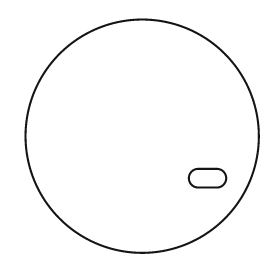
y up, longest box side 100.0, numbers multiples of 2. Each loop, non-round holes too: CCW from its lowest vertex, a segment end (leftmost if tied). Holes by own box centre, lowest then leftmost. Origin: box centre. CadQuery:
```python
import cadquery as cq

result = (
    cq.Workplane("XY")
    .moveTo(0.0, 0.0)
    .circle(50.0)
    .moveTo(24.0, -22.0)
    .lineTo(32.0, -22.0)
    .threePointArc((36.0, -18.0), (32.0, -14.0))
    .lineTo(24.0, -14.0)
    .threePointArc((20.0, -18.0), (24.0, -22.0))
    .close()
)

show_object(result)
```